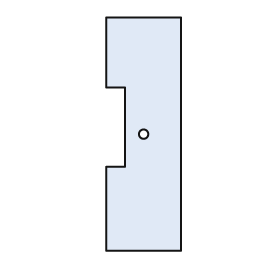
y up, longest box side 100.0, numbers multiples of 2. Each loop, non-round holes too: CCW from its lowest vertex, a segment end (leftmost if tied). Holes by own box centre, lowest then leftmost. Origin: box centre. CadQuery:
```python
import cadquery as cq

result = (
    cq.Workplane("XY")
    .moveTo(-16.0, -50.0)
    .lineTo(16.0, -50.0)
    .lineTo(16.0, 50.0)
    .lineTo(-16.0, 50.0)
    .lineTo(-16.0, 20.0)
    .lineTo(-8.0, 20.0)
    .lineTo(-8.0, -14.0)
    .lineTo(-16.0, -14.0)
    .close()
    .moveTo(0.0, 0.0)
    .circle(2.0)
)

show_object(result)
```